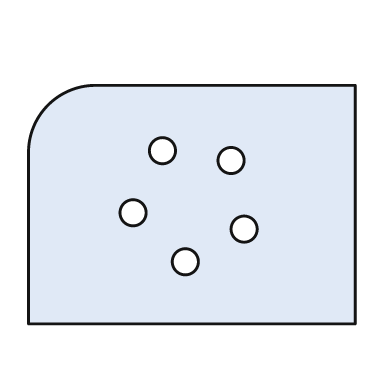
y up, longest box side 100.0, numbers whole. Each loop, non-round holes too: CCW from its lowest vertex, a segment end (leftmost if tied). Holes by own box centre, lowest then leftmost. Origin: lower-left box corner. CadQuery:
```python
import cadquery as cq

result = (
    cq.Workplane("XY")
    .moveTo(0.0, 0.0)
    .lineTo(100.0, 0.0)
    .lineTo(100.0, 73.0)
    .lineTo(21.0, 73.0)
    .threePointArc((6.0, 67.0), (0.0, 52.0))
    .close()
    .moveTo(48.0, 19.0)
    .circle(4.0)
    .moveTo(66.0, 29.0)
    .circle(4.0)
    .moveTo(32.0, 34.0)
    .circle(4.0)
    .moveTo(62.0, 50.0)
    .circle(4.0)
    .moveTo(41.0, 53.0)
    .circle(4.0)
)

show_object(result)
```